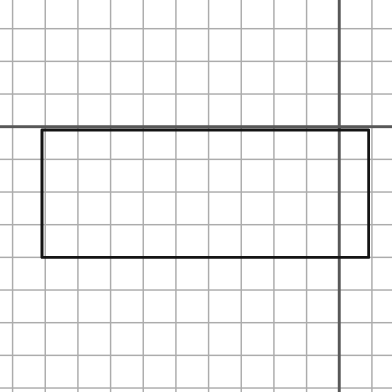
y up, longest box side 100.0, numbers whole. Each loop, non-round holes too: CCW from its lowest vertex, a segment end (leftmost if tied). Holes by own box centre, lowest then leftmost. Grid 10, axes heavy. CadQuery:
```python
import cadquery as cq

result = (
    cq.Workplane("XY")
    .moveTo(-91.0, -40.0)
    .lineTo(9.0, -40.0)
    .lineTo(9.0, -1.0)
    .lineTo(-91.0, -1.0)
    .close()
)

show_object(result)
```